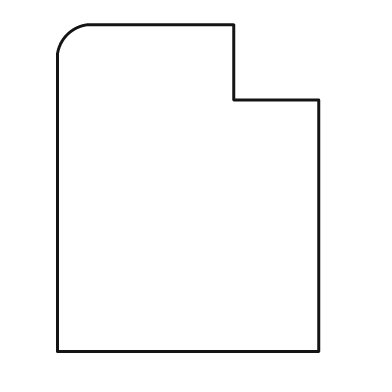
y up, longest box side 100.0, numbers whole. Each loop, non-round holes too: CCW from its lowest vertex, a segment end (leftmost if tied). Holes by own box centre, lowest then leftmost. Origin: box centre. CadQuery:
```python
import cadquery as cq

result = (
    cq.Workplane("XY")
    .moveTo(-40.0, -50.0)
    .lineTo(40.0, -50.0)
    .lineTo(40.0, 27.0)
    .lineTo(14.0, 27.0)
    .lineTo(14.0, 50.0)
    .lineTo(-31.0, 50.0)
    .threePointArc((-37.0, 47.0), (-40.0, 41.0))
    .close()
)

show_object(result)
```